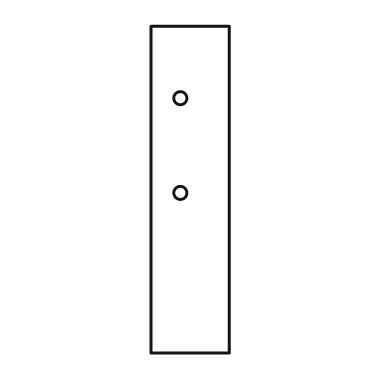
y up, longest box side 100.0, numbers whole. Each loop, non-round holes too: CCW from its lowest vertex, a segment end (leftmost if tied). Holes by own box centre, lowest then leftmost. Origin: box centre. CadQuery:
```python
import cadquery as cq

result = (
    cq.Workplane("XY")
    .moveTo(-12.0, -50.0)
    .lineTo(12.0, -50.0)
    .lineTo(12.0, 50.0)
    .lineTo(-12.0, 50.0)
    .close()
    .moveTo(-3.0, -1.0)
    .circle(2.0)
    .moveTo(-3.0, 28.0)
    .circle(2.0)
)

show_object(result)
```